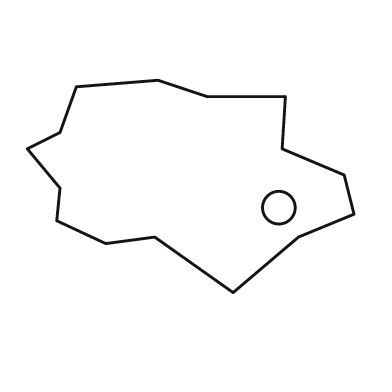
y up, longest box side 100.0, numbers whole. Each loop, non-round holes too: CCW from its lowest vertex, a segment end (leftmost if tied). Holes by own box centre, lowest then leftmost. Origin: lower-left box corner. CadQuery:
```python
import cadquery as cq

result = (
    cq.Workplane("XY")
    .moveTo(63.0, 0.0)
    .lineTo(83.0, 17.0)
    .lineTo(100.0, 24.0)
    .lineTo(97.0, 36.0)
    .lineTo(78.0, 44.0)
    .lineTo(79.0, 60.0)
    .lineTo(55.0, 60.0)
    .lineTo(40.0, 65.0)
    .lineTo(15.0, 63.0)
    .lineTo(10.0, 49.0)
    .lineTo(0.0, 44.0)
    .lineTo(10.0, 32.0)
    .lineTo(9.0, 22.0)
    .lineTo(24.0, 15.0)
    .lineTo(39.0, 17.0)
    .close()
    .moveTo(77.0, 26.0)
    .circle(5.0)
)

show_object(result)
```